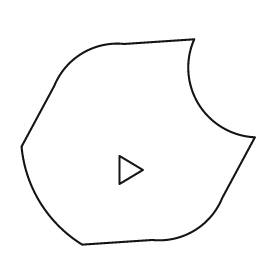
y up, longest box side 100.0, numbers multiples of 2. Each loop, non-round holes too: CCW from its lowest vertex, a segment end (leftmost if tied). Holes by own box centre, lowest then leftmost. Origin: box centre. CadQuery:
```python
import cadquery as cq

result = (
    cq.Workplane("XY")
    .moveTo(-24.0, -44.0)
    .lineTo(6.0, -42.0)
    .threePointArc((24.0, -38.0), (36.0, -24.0))
    .lineTo(50.0, 2.0)
    .threePointArc((26.0, 16.0), (24.0, 44.0))
    .lineTo(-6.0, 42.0)
    .threePointArc((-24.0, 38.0), (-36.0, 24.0))
    .lineTo(-50.0, -2.0)
    .threePointArc((-42.0, -26.0), (-24.0, -44.0))
    .close()
    .moveTo(-8.0, -18.0)
    .lineTo(2.0, -12.0)
    .lineTo(-8.0, -6.0)
    .close()
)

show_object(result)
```